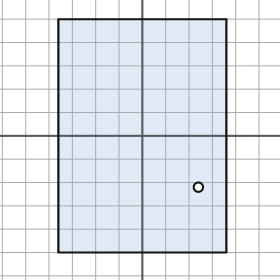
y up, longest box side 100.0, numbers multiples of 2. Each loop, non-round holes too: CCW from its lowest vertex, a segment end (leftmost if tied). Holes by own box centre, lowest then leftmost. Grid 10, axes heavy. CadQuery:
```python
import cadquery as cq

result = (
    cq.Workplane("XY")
    .moveTo(-36.0, -50.0)
    .lineTo(36.0, -50.0)
    .lineTo(36.0, 50.0)
    .lineTo(-36.0, 50.0)
    .close()
    .moveTo(24.0, -22.0)
    .circle(2.0)
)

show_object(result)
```